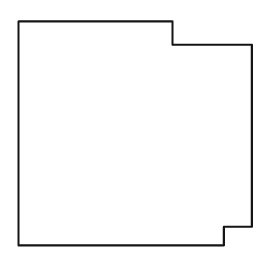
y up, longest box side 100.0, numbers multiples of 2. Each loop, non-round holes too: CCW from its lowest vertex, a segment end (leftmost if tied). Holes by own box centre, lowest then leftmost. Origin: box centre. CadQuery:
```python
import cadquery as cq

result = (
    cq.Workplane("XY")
    .moveTo(-50.0, -48.0)
    .lineTo(38.0, -48.0)
    .lineTo(38.0, -40.0)
    .lineTo(50.0, -40.0)
    .lineTo(50.0, 38.0)
    .lineTo(16.0, 38.0)
    .lineTo(16.0, 48.0)
    .lineTo(-50.0, 48.0)
    .close()
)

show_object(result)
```